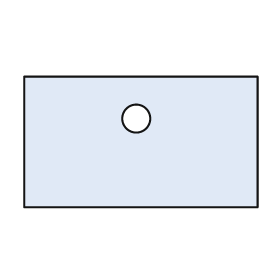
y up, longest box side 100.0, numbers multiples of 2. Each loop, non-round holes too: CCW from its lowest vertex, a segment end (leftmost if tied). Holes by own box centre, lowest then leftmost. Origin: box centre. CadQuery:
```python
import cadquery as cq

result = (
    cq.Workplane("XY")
    .moveTo(-50.0, -28.0)
    .lineTo(50.0, -28.0)
    .lineTo(50.0, 28.0)
    .lineTo(-50.0, 28.0)
    .close()
    .moveTo(-2.0, 10.0)
    .circle(6.0)
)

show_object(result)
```